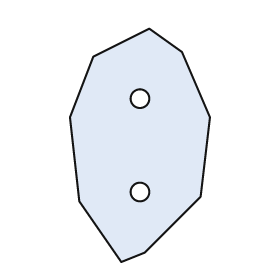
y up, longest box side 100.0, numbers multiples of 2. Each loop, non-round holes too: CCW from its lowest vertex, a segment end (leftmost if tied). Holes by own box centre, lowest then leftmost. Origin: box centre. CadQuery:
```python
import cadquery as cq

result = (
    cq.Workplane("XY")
    .moveTo(-8.0, -50.0)
    .lineTo(2.0, -46.0)
    .lineTo(26.0, -22.0)
    .lineTo(30.0, 12.0)
    .lineTo(18.0, 40.0)
    .lineTo(4.0, 50.0)
    .lineTo(-20.0, 38.0)
    .lineTo(-30.0, 12.0)
    .lineTo(-26.0, -24.0)
    .close()
    .moveTo(0.0, -20.0)
    .circle(4.0)
    .moveTo(0.0, 20.0)
    .circle(4.0)
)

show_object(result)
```